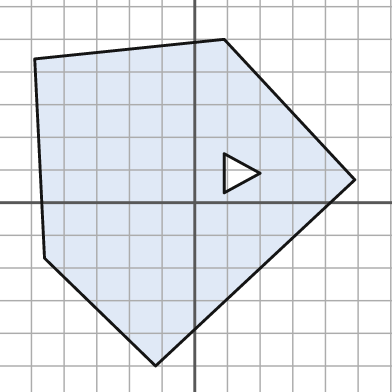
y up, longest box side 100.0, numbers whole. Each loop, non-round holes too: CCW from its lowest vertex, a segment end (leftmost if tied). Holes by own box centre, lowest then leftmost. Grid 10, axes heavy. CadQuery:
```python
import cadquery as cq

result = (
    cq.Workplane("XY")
    .moveTo(-12.0, -50.0)
    .lineTo(49.0, 7.0)
    .lineTo(9.0, 50.0)
    .lineTo(-49.0, 44.0)
    .lineTo(-46.0, -17.0)
    .close()
    .moveTo(9.0, 3.0)
    .lineTo(20.0, 9.0)
    .lineTo(9.0, 15.0)
    .close()
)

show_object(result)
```